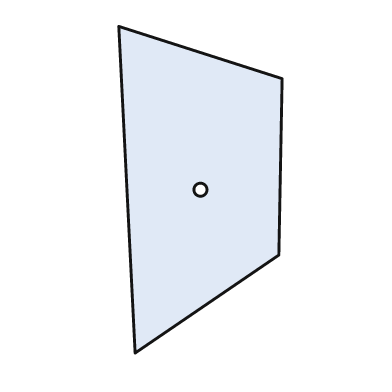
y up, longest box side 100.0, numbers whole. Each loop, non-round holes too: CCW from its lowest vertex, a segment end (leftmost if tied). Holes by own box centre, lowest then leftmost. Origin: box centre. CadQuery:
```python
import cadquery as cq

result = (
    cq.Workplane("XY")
    .moveTo(-20.0, -50.0)
    .lineTo(24.0, -20.0)
    .lineTo(25.0, 34.0)
    .lineTo(-25.0, 50.0)
    .close()
    .moveTo(0.0, 0.0)
    .circle(2.0)
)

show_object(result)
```